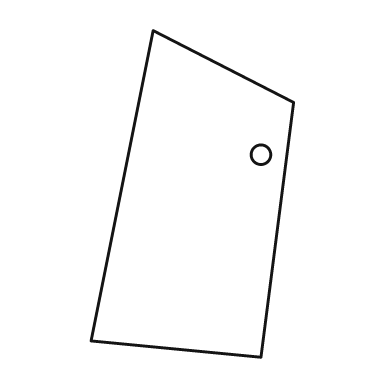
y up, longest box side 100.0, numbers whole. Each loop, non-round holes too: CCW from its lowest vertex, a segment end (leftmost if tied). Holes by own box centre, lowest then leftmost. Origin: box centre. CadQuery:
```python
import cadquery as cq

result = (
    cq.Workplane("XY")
    .moveTo(21.0, -50.0)
    .lineTo(31.0, 28.0)
    .lineTo(-12.0, 50.0)
    .lineTo(-31.0, -45.0)
    .close()
    .moveTo(21.0, 12.0)
    .circle(3.0)
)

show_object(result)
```